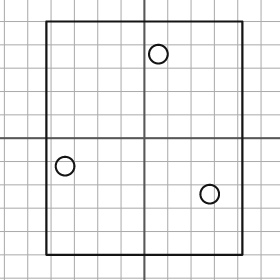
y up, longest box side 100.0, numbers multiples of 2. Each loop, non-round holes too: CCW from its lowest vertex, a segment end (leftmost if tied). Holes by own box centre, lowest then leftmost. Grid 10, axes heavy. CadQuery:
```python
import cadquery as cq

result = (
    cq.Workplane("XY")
    .moveTo(-42.0, -50.0)
    .lineTo(42.0, -50.0)
    .lineTo(42.0, 50.0)
    .lineTo(-42.0, 50.0)
    .close()
    .moveTo(28.0, -24.0)
    .circle(4.0)
    .moveTo(-34.0, -12.0)
    .circle(4.0)
    .moveTo(6.0, 36.0)
    .circle(4.0)
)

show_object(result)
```